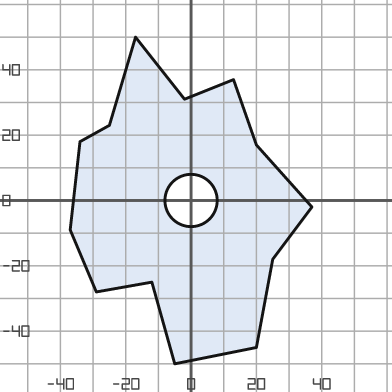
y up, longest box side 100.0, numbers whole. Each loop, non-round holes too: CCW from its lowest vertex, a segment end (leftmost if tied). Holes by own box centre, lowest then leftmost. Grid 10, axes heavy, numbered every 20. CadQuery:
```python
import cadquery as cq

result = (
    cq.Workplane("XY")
    .moveTo(-5.0, -50.0)
    .lineTo(20.0, -45.0)
    .lineTo(25.0, -18.0)
    .lineTo(37.0, -2.0)
    .lineTo(20.0, 17.0)
    .lineTo(13.0, 37.0)
    .lineTo(-2.0, 31.0)
    .lineTo(-17.0, 50.0)
    .lineTo(-25.0, 23.0)
    .lineTo(-34.0, 18.0)
    .lineTo(-37.0, -9.0)
    .lineTo(-29.0, -28.0)
    .lineTo(-12.0, -25.0)
    .close()
    .moveTo(0.0, 0.0)
    .circle(8.0)
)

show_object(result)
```